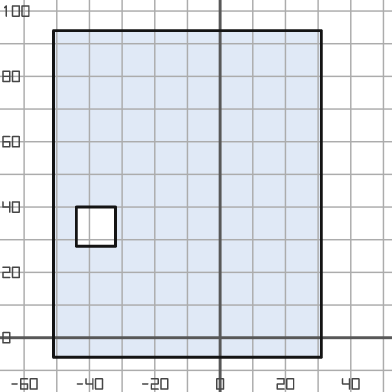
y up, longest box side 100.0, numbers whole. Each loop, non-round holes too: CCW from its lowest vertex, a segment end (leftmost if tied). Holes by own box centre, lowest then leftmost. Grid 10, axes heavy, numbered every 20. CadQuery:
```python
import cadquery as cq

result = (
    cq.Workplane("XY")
    .moveTo(-51.0, -6.0)
    .lineTo(31.0, -6.0)
    .lineTo(31.0, 94.0)
    .lineTo(-51.0, 94.0)
    .close()
    .moveTo(-44.0, 28.0)
    .lineTo(-32.0, 28.0)
    .lineTo(-32.0, 40.0)
    .lineTo(-44.0, 40.0)
    .close()
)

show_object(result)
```